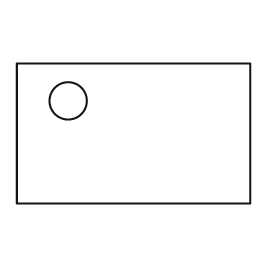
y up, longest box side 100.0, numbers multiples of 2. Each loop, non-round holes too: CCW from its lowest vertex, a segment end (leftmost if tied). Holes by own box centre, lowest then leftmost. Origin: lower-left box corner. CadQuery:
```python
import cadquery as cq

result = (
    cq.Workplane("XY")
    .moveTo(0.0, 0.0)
    .lineTo(100.0, 0.0)
    .lineTo(100.0, 60.0)
    .lineTo(0.0, 60.0)
    .close()
    .moveTo(22.0, 44.0)
    .circle(8.0)
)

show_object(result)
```